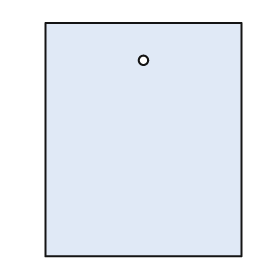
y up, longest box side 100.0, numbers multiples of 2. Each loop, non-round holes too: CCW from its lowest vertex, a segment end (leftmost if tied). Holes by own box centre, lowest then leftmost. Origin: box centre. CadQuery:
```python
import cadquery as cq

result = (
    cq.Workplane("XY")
    .moveTo(-42.0, -50.0)
    .lineTo(42.0, -50.0)
    .lineTo(42.0, 50.0)
    .lineTo(-42.0, 50.0)
    .close()
    .moveTo(0.0, 34.0)
    .circle(2.0)
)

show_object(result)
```